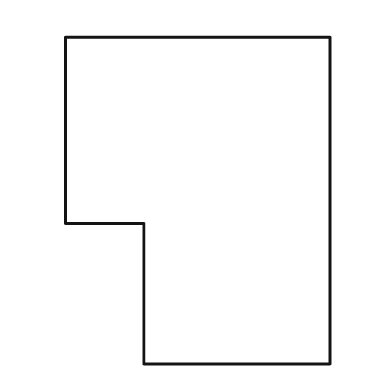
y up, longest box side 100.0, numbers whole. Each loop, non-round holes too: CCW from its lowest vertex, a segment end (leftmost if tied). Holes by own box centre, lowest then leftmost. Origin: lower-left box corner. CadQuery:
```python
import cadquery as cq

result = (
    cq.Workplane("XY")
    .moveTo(24.0, 0.0)
    .lineTo(81.0, 0.0)
    .lineTo(81.0, 100.0)
    .lineTo(0.0, 100.0)
    .lineTo(0.0, 43.0)
    .lineTo(24.0, 43.0)
    .close()
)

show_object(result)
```